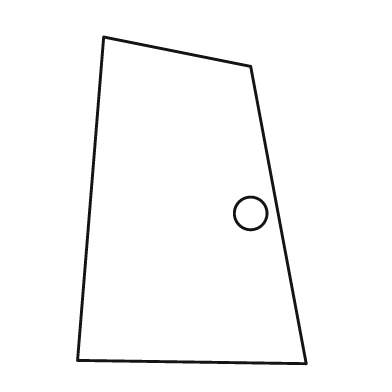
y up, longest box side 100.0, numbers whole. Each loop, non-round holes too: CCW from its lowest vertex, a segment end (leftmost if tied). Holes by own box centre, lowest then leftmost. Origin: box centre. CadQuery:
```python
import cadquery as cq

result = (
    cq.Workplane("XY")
    .moveTo(35.0, -50.0)
    .lineTo(18.0, 41.0)
    .lineTo(-27.0, 50.0)
    .lineTo(-35.0, -49.0)
    .close()
    .moveTo(18.0, -4.0)
    .circle(5.0)
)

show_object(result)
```